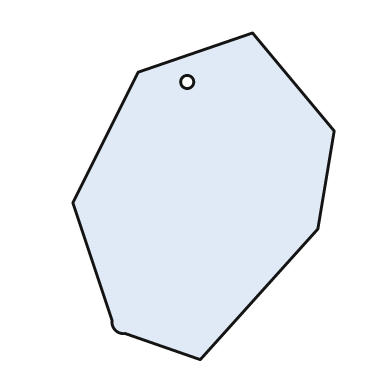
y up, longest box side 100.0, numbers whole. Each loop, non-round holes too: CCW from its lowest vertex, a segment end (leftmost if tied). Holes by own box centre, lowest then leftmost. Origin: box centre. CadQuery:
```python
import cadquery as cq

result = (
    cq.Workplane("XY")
    .moveTo(-1.0, -50.0)
    .lineTo(35.0, -10.0)
    .lineTo(40.0, 20.0)
    .lineTo(15.0, 50.0)
    .lineTo(-20.0, 38.0)
    .lineTo(-40.0, -2.0)
    .lineTo(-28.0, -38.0)
    .threePointArc((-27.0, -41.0), (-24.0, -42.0))
    .close()
    .moveTo(-5.0, 35.0)
    .circle(2.0)
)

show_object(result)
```